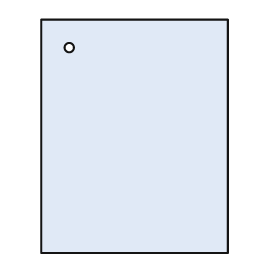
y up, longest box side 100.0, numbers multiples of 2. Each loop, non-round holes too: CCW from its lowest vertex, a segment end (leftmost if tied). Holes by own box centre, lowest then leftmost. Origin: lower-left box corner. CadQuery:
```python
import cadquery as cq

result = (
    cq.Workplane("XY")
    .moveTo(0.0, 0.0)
    .lineTo(80.0, 0.0)
    .lineTo(80.0, 100.0)
    .lineTo(0.0, 100.0)
    .close()
    .moveTo(12.0, 88.0)
    .circle(2.0)
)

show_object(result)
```